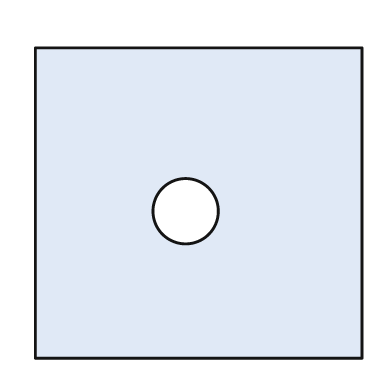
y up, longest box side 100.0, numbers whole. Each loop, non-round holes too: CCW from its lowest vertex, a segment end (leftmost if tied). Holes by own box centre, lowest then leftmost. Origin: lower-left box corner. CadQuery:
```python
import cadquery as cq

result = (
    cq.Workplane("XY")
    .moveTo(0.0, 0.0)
    .lineTo(100.0, 0.0)
    .lineTo(100.0, 95.0)
    .lineTo(0.0, 95.0)
    .close()
    .moveTo(46.0, 45.0)
    .circle(10.0)
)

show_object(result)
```